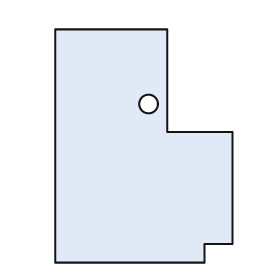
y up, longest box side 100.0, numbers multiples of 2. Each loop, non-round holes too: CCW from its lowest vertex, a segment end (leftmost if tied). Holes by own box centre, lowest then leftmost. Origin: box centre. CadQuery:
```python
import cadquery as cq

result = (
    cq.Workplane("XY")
    .moveTo(-38.0, -50.0)
    .lineTo(26.0, -50.0)
    .lineTo(26.0, -42.0)
    .lineTo(38.0, -42.0)
    .lineTo(38.0, 6.0)
    .lineTo(10.0, 6.0)
    .lineTo(10.0, 50.0)
    .lineTo(-38.0, 50.0)
    .close()
    .moveTo(2.0, 18.0)
    .circle(4.0)
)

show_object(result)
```